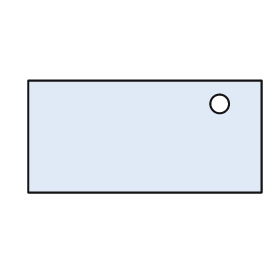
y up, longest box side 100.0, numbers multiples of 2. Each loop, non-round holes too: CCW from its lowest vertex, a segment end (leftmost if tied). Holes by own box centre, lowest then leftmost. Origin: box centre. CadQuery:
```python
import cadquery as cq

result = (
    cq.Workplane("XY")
    .moveTo(-50.0, -24.0)
    .lineTo(50.0, -24.0)
    .lineTo(50.0, 24.0)
    .lineTo(-50.0, 24.0)
    .close()
    .moveTo(32.0, 14.0)
    .circle(4.0)
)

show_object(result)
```